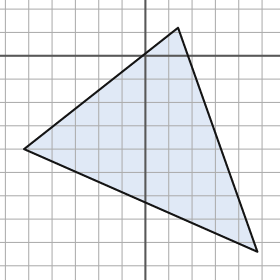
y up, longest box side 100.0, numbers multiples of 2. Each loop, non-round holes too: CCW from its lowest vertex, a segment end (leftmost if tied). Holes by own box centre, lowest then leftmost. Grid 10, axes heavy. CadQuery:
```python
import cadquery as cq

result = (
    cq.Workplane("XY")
    .moveTo(48.0, -84.0)
    .lineTo(14.0, 12.0)
    .lineTo(-52.0, -40.0)
    .close()
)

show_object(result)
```